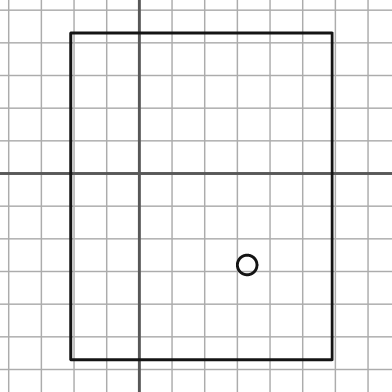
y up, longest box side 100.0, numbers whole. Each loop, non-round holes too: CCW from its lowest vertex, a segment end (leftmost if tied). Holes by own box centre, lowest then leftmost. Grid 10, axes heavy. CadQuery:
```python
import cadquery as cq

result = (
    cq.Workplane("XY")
    .moveTo(-21.0, -57.0)
    .lineTo(59.0, -57.0)
    .lineTo(59.0, 43.0)
    .lineTo(-21.0, 43.0)
    .close()
    .moveTo(33.0, -28.0)
    .circle(3.0)
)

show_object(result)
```